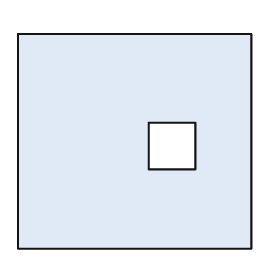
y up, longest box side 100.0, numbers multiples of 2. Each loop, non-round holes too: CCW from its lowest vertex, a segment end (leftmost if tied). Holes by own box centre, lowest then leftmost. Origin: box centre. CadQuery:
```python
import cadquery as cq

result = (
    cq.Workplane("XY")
    .moveTo(-50.0, -46.0)
    .lineTo(50.0, -46.0)
    .lineTo(50.0, 46.0)
    .lineTo(-50.0, 46.0)
    .close()
    .moveTo(6.0, -12.0)
    .lineTo(26.0, -12.0)
    .lineTo(26.0, 8.0)
    .lineTo(6.0, 8.0)
    .close()
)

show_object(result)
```